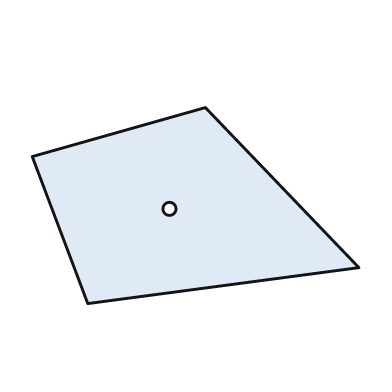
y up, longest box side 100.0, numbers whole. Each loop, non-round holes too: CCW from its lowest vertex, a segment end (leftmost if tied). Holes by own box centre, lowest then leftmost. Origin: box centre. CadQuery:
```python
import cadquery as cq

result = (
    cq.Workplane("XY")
    .moveTo(-33.0, -30.0)
    .lineTo(50.0, -19.0)
    .lineTo(3.0, 30.0)
    .lineTo(-50.0, 15.0)
    .close()
    .moveTo(-8.0, -1.0)
    .circle(2.0)
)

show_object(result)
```